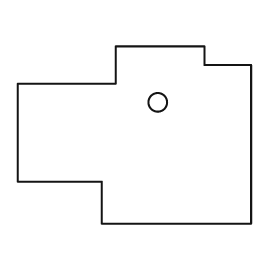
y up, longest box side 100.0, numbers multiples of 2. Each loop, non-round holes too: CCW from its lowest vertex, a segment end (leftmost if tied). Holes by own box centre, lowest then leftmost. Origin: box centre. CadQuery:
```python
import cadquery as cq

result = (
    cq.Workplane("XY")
    .moveTo(-14.0, -38.0)
    .lineTo(50.0, -38.0)
    .lineTo(50.0, 30.0)
    .lineTo(30.0, 30.0)
    .lineTo(30.0, 38.0)
    .lineTo(-8.0, 38.0)
    .lineTo(-8.0, 22.0)
    .lineTo(-50.0, 22.0)
    .lineTo(-50.0, -20.0)
    .lineTo(-14.0, -20.0)
    .close()
    .moveTo(10.0, 14.0)
    .circle(4.0)
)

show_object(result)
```